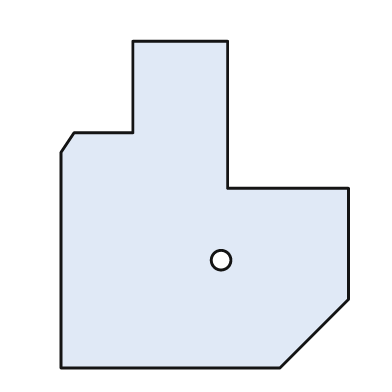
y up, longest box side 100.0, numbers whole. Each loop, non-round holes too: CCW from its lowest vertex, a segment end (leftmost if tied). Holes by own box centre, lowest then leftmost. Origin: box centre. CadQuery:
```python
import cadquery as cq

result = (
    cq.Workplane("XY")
    .moveTo(-44.0, -50.0)
    .lineTo(23.0, -50.0)
    .lineTo(44.0, -29.0)
    .lineTo(44.0, 5.0)
    .lineTo(7.0, 5.0)
    .lineTo(7.0, 50.0)
    .lineTo(-22.0, 50.0)
    .lineTo(-22.0, 22.0)
    .lineTo(-40.0, 22.0)
    .lineTo(-44.0, 16.0)
    .close()
    .moveTo(5.0, -17.0)
    .circle(3.0)
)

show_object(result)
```